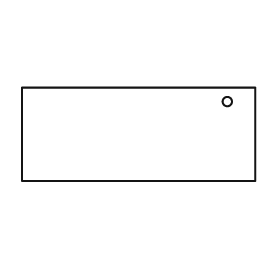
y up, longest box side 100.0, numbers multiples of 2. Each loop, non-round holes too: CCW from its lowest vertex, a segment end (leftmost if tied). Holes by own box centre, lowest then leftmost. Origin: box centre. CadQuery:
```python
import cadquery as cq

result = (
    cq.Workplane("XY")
    .moveTo(-50.0, -20.0)
    .lineTo(50.0, -20.0)
    .lineTo(50.0, 20.0)
    .lineTo(-50.0, 20.0)
    .close()
    .moveTo(38.0, 14.0)
    .circle(2.0)
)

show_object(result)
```